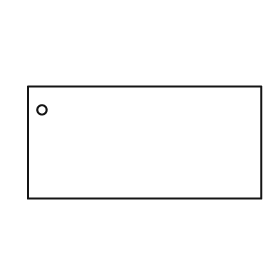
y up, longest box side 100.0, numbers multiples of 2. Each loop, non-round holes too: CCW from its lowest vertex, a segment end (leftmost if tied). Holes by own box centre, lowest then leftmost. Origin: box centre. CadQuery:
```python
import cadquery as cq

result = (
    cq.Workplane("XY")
    .moveTo(-50.0, -24.0)
    .lineTo(50.0, -24.0)
    .lineTo(50.0, 24.0)
    .lineTo(-50.0, 24.0)
    .close()
    .moveTo(-44.0, 14.0)
    .circle(2.0)
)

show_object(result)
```